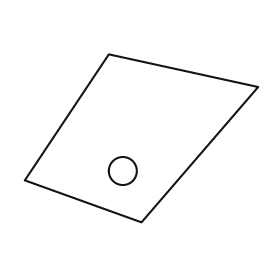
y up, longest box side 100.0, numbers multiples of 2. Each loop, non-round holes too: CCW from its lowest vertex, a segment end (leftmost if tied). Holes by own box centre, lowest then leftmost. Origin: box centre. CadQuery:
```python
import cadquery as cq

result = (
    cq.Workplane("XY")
    .moveTo(0.0, -36.0)
    .lineTo(50.0, 22.0)
    .lineTo(-14.0, 36.0)
    .lineTo(-50.0, -18.0)
    .close()
    .moveTo(-8.0, -14.0)
    .circle(6.0)
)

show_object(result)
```